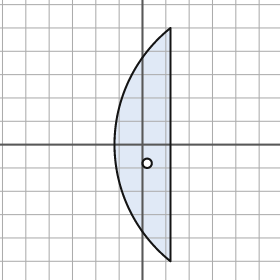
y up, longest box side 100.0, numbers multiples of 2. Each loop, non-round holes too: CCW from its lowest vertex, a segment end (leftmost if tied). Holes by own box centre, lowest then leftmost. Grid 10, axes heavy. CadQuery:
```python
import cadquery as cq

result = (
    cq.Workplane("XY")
    .moveTo(12.0, -50.0)
    .lineTo(12.0, 50.0)
    .threePointArc((-12.0, 0.0), (12.0, -50.0))
    .close()
    .moveTo(2.0, -8.0)
    .circle(2.0)
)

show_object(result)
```